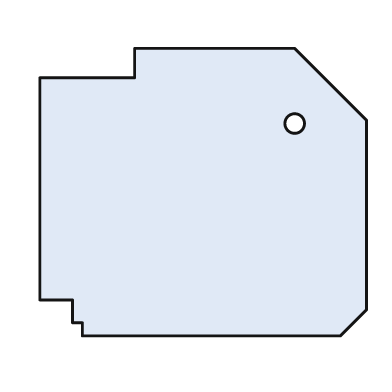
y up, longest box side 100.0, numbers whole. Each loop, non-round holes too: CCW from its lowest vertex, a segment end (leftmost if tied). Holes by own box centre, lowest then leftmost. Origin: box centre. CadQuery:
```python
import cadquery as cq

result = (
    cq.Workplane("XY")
    .moveTo(-37.0, -44.0)
    .lineTo(42.0, -44.0)
    .lineTo(50.0, -36.0)
    .lineTo(50.0, 22.0)
    .lineTo(28.0, 44.0)
    .lineTo(-21.0, 44.0)
    .lineTo(-21.0, 35.0)
    .lineTo(-50.0, 35.0)
    .lineTo(-50.0, -33.0)
    .lineTo(-40.0, -33.0)
    .lineTo(-40.0, -40.0)
    .lineTo(-37.0, -40.0)
    .close()
    .moveTo(28.0, 21.0)
    .circle(3.0)
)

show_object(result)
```